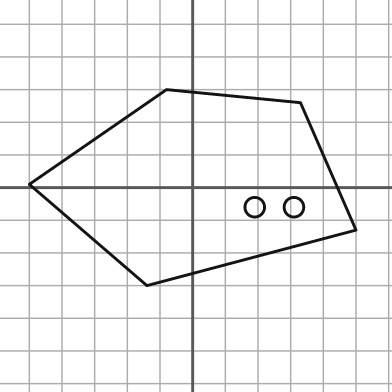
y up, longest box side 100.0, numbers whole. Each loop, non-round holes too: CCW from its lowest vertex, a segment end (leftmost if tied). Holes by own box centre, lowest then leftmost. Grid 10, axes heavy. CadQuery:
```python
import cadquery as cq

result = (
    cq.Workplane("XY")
    .moveTo(-14.0, -30.0)
    .lineTo(50.0, -13.0)
    .lineTo(33.0, 26.0)
    .lineTo(-8.0, 30.0)
    .lineTo(-50.0, 1.0)
    .close()
    .moveTo(19.0, -6.0)
    .circle(3.0)
    .moveTo(31.0, -6.0)
    .circle(3.0)
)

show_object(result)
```